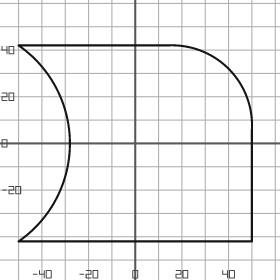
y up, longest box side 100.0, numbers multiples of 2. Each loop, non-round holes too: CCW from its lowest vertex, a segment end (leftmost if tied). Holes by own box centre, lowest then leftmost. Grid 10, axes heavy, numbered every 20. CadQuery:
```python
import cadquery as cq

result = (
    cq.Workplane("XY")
    .moveTo(-50.0, -42.0)
    .lineTo(50.0, -42.0)
    .lineTo(50.0, 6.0)
    .threePointArc((40.0, 32.0), (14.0, 42.0))
    .lineTo(-50.0, 42.0)
    .threePointArc((-28.0, 0.0), (-50.0, -42.0))
    .close()
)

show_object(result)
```